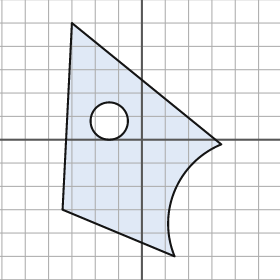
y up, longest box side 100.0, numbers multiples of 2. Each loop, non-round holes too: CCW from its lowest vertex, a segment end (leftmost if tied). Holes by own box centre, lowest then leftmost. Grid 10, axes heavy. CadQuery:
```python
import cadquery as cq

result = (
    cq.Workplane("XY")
    .moveTo(14.0, -50.0)
    .threePointArc((14.0, -22.0), (34.0, -2.0))
    .lineTo(-30.0, 50.0)
    .lineTo(-34.0, -30.0)
    .close()
    .moveTo(-14.0, 8.0)
    .circle(8.0)
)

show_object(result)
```